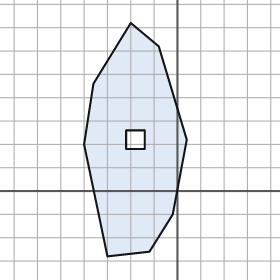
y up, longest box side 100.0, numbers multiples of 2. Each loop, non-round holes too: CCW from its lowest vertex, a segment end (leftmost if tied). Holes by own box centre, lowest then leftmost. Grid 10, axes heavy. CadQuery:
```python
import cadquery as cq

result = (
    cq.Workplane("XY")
    .moveTo(-30.0, -28.0)
    .lineTo(-12.0, -26.0)
    .lineTo(-2.0, -10.0)
    .lineTo(4.0, 22.0)
    .lineTo(-8.0, 62.0)
    .lineTo(-20.0, 72.0)
    .lineTo(-36.0, 46.0)
    .lineTo(-40.0, 20.0)
    .close()
    .moveTo(-22.0, 18.0)
    .lineTo(-14.0, 18.0)
    .lineTo(-14.0, 26.0)
    .lineTo(-22.0, 26.0)
    .close()
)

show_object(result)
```